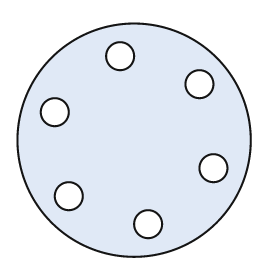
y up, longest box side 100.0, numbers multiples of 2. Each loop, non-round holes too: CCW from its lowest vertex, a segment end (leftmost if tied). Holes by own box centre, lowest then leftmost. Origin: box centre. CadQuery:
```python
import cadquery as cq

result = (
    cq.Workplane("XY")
    .moveTo(0.0, 0.0)
    .circle(50.0)
    .moveTo(6.0, -36.0)
    .circle(6.0)
    .moveTo(-28.0, -24.0)
    .circle(6.0)
    .moveTo(34.0, -12.0)
    .circle(6.0)
    .moveTo(-34.0, 12.0)
    .circle(6.0)
    .moveTo(28.0, 24.0)
    .circle(6.0)
    .moveTo(-6.0, 36.0)
    .circle(6.0)
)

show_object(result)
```